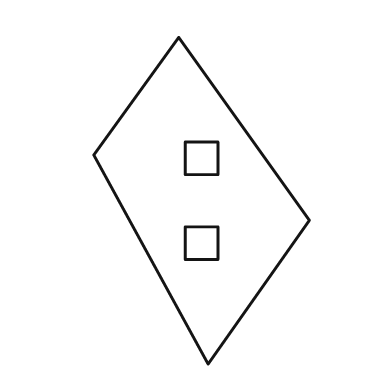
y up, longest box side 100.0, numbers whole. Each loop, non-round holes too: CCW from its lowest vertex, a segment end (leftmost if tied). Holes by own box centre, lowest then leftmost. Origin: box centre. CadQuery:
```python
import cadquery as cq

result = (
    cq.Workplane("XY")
    .moveTo(2.0, -50.0)
    .lineTo(33.0, -6.0)
    .lineTo(-7.0, 50.0)
    .lineTo(-33.0, 14.0)
    .close()
    .moveTo(-5.0, -18.0)
    .lineTo(5.0, -18.0)
    .lineTo(5.0, -8.0)
    .lineTo(-5.0, -8.0)
    .close()
    .moveTo(-5.0, 8.0)
    .lineTo(5.0, 8.0)
    .lineTo(5.0, 18.0)
    .lineTo(-5.0, 18.0)
    .close()
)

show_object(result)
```